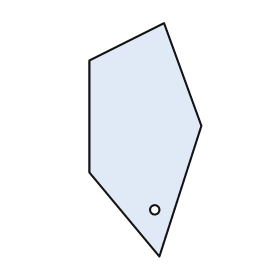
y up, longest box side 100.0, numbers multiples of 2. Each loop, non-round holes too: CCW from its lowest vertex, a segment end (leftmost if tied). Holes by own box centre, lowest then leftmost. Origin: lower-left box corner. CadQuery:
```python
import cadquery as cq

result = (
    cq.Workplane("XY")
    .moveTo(30.0, 0.0)
    .lineTo(48.0, 56.0)
    .lineTo(32.0, 100.0)
    .lineTo(0.0, 84.0)
    .lineTo(0.0, 36.0)
    .close()
    .moveTo(28.0, 20.0)
    .circle(2.0)
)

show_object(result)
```